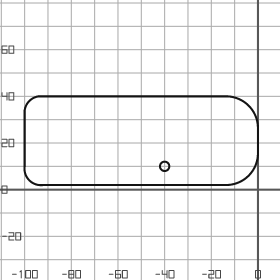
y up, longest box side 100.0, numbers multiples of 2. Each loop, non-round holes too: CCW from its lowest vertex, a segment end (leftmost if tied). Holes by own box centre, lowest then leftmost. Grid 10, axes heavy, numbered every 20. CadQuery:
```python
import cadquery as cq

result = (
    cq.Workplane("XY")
    .moveTo(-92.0, 2.0)
    .lineTo(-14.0, 2.0)
    .threePointArc((-4.0, 6.0), (0.0, 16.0))
    .lineTo(0.0, 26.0)
    .threePointArc((-4.0, 36.0), (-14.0, 40.0))
    .lineTo(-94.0, 40.0)
    .threePointArc((-98.0, 38.0), (-100.0, 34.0))
    .lineTo(-100.0, 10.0)
    .threePointArc((-98.0, 4.0), (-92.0, 2.0))
    .close()
    .moveTo(-40.0, 10.0)
    .circle(2.0)
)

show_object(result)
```